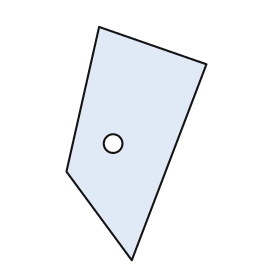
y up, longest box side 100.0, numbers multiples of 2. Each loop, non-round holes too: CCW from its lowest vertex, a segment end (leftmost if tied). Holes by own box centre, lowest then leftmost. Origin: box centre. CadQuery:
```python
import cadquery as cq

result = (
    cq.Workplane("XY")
    .moveTo(-2.0, -50.0)
    .lineTo(30.0, 34.0)
    .lineTo(-16.0, 50.0)
    .lineTo(-30.0, -12.0)
    .close()
    .moveTo(-10.0, 0.0)
    .circle(4.0)
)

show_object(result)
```